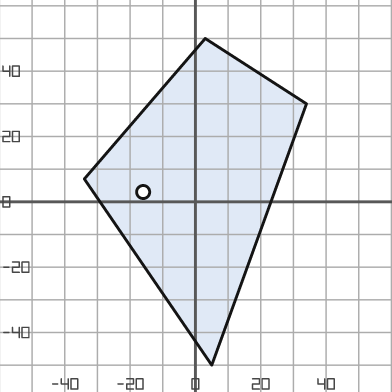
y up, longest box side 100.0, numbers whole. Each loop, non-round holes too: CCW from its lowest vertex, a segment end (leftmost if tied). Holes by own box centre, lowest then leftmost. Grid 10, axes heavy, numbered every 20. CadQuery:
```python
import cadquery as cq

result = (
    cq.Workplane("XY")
    .moveTo(5.0, -50.0)
    .lineTo(34.0, 30.0)
    .lineTo(3.0, 50.0)
    .lineTo(-34.0, 7.0)
    .close()
    .moveTo(-16.0, 3.0)
    .circle(2.0)
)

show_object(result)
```